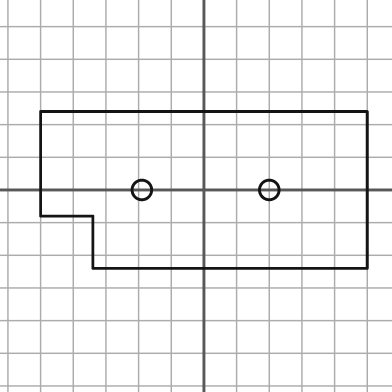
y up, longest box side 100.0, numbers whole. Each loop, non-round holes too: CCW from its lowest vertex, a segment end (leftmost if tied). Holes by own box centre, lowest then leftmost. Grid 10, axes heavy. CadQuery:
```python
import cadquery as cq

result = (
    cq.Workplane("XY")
    .moveTo(-34.0, -24.0)
    .lineTo(50.0, -24.0)
    .lineTo(50.0, 24.0)
    .lineTo(-50.0, 24.0)
    .lineTo(-50.0, -8.0)
    .lineTo(-34.0, -8.0)
    .close()
    .moveTo(-19.0, 0.0)
    .circle(3.0)
    .moveTo(20.0, 0.0)
    .circle(3.0)
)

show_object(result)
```